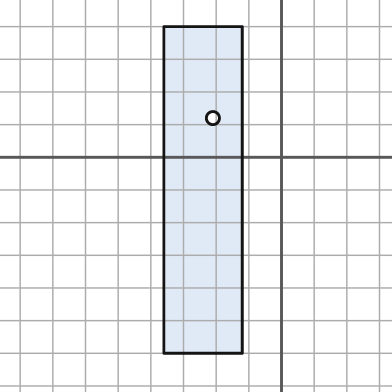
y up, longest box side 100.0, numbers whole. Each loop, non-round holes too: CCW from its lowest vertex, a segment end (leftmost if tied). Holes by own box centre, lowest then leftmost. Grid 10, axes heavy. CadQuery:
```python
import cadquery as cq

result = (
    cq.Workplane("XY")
    .moveTo(-36.0, -60.0)
    .lineTo(-12.0, -60.0)
    .lineTo(-12.0, 40.0)
    .lineTo(-36.0, 40.0)
    .close()
    .moveTo(-21.0, 12.0)
    .circle(2.0)
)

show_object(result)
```